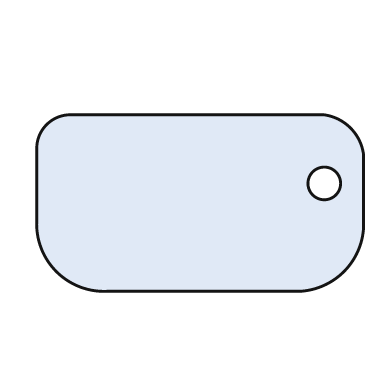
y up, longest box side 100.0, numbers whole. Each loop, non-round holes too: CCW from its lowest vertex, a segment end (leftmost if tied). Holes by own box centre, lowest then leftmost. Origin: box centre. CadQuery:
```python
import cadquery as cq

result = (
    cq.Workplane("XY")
    .moveTo(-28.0, -27.0)
    .lineTo(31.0, -27.0)
    .threePointArc((44.0, -21.0), (50.0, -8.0))
    .lineTo(50.0, 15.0)
    .threePointArc((46.0, 23.0), (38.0, 27.0))
    .lineTo(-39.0, 27.0)
    .threePointArc((-47.0, 24.0), (-50.0, 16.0))
    .lineTo(-50.0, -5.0)
    .threePointArc((-44.0, -21.0), (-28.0, -27.0))
    .close()
    .moveTo(38.0, 6.0)
    .circle(5.0)
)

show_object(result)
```